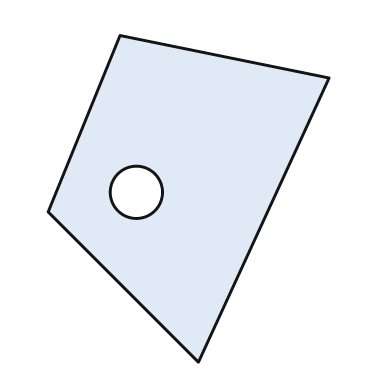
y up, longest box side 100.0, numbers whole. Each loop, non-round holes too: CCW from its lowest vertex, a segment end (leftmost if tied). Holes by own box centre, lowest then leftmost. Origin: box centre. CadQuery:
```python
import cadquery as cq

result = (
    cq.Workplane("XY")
    .moveTo(3.0, -50.0)
    .lineTo(43.0, 37.0)
    .lineTo(-21.0, 50.0)
    .lineTo(-43.0, -4.0)
    .close()
    .moveTo(-16.0, 2.0)
    .circle(8.0)
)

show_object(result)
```